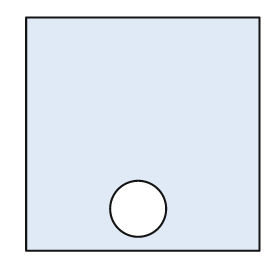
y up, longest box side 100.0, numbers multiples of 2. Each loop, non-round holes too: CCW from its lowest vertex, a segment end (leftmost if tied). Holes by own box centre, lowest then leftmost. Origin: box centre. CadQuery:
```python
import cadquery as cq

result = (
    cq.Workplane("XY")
    .moveTo(-50.0, -50.0)
    .lineTo(50.0, -50.0)
    .lineTo(50.0, 50.0)
    .lineTo(-50.0, 50.0)
    .close()
    .moveTo(-2.0, -32.0)
    .circle(12.0)
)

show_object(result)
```